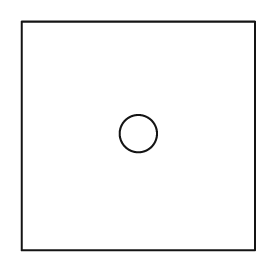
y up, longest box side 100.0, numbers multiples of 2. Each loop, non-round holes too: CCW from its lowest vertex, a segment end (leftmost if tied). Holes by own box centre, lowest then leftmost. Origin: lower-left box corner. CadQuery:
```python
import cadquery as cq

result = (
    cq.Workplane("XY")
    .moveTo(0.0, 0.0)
    .lineTo(100.0, 0.0)
    .lineTo(100.0, 98.0)
    .lineTo(0.0, 98.0)
    .close()
    .moveTo(50.0, 50.0)
    .circle(8.0)
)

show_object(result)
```